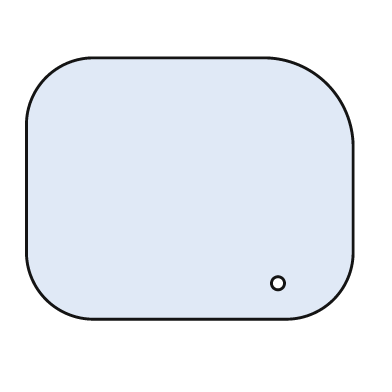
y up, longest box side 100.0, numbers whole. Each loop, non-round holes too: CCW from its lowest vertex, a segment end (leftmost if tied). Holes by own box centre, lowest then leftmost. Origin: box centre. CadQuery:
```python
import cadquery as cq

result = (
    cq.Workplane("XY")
    .moveTo(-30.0, -40.0)
    .lineTo(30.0, -40.0)
    .threePointArc((44.0, -34.0), (50.0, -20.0))
    .lineTo(50.0, 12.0)
    .threePointArc((42.0, 32.0), (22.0, 40.0))
    .lineTo(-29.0, 40.0)
    .threePointArc((-44.0, 34.0), (-50.0, 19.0))
    .lineTo(-50.0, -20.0)
    .threePointArc((-44.0, -34.0), (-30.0, -40.0))
    .close()
    .moveTo(27.0, -29.0)
    .circle(2.0)
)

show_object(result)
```